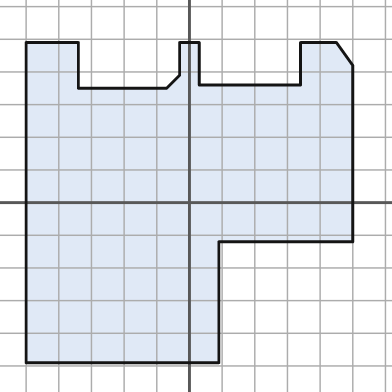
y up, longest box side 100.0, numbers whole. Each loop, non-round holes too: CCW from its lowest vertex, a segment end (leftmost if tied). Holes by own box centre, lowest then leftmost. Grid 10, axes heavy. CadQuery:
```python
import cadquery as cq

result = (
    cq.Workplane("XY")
    .moveTo(-50.0, -49.0)
    .lineTo(9.0, -49.0)
    .lineTo(9.0, -12.0)
    .lineTo(50.0, -12.0)
    .lineTo(50.0, 42.0)
    .lineTo(45.0, 49.0)
    .lineTo(34.0, 49.0)
    .lineTo(34.0, 36.0)
    .lineTo(3.0, 36.0)
    .lineTo(3.0, 49.0)
    .lineTo(-3.0, 49.0)
    .lineTo(-3.0, 39.0)
    .lineTo(-7.0, 35.0)
    .lineTo(-34.0, 35.0)
    .lineTo(-34.0, 49.0)
    .lineTo(-50.0, 49.0)
    .close()
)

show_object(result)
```